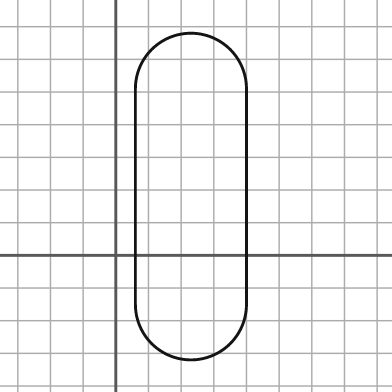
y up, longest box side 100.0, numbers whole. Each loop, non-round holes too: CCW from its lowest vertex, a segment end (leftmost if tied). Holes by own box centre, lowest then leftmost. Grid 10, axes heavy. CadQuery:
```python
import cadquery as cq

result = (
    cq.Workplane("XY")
    .moveTo(6.0, -15.0)
    .threePointArc((23.0, -32.0), (40.0, -15.0))
    .lineTo(40.0, 51.0)
    .threePointArc((23.0, 68.0), (6.0, 51.0))
    .close()
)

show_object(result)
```